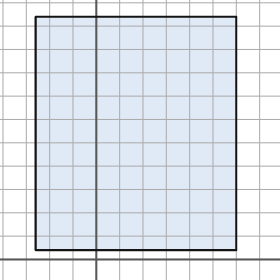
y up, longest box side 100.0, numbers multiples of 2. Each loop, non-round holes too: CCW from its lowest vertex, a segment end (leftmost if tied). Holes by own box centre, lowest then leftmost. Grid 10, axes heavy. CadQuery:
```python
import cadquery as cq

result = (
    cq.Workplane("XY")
    .moveTo(-26.0, 4.0)
    .lineTo(60.0, 4.0)
    .lineTo(60.0, 104.0)
    .lineTo(-26.0, 104.0)
    .close()
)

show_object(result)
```